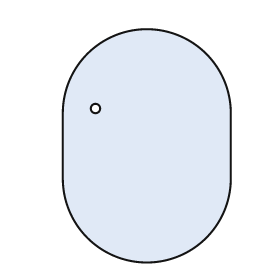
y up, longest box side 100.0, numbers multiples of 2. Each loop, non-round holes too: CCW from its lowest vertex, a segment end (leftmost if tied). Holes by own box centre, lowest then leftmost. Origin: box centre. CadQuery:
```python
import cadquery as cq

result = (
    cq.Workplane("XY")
    .moveTo(-36.0, -14.0)
    .threePointArc((0.0, -50.0), (36.0, -14.0))
    .lineTo(36.0, 14.0)
    .threePointArc((0.0, 50.0), (-36.0, 14.0))
    .close()
    .moveTo(-22.0, 16.0)
    .circle(2.0)
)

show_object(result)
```